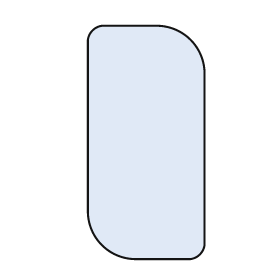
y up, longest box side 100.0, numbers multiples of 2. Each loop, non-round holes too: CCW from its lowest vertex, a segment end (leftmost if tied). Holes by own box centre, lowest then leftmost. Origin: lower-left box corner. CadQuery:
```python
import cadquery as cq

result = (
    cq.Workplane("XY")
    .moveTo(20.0, 0.0)
    .lineTo(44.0, 0.0)
    .threePointArc((48.0, 2.0), (50.0, 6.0))
    .lineTo(50.0, 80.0)
    .threePointArc((44.0, 94.0), (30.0, 100.0))
    .lineTo(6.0, 100.0)
    .threePointArc((2.0, 98.0), (0.0, 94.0))
    .lineTo(0.0, 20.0)
    .threePointArc((6.0, 6.0), (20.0, 0.0))
    .close()
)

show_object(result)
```